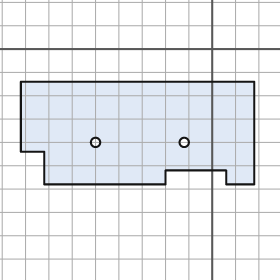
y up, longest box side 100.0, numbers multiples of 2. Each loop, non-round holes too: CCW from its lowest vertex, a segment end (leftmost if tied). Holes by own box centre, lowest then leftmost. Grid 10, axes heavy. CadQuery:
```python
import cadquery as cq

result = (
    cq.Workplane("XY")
    .moveTo(-72.0, -58.0)
    .lineTo(-20.0, -58.0)
    .lineTo(-20.0, -52.0)
    .lineTo(6.0, -52.0)
    .lineTo(6.0, -58.0)
    .lineTo(18.0, -58.0)
    .lineTo(18.0, -14.0)
    .lineTo(-82.0, -14.0)
    .lineTo(-82.0, -44.0)
    .lineTo(-72.0, -44.0)
    .close()
    .moveTo(-50.0, -40.0)
    .circle(2.0)
    .moveTo(-12.0, -40.0)
    .circle(2.0)
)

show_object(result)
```